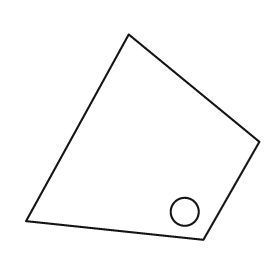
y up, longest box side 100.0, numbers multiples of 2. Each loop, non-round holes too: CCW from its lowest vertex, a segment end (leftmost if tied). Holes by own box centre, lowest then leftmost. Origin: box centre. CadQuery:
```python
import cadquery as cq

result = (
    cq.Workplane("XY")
    .moveTo(26.0, -44.0)
    .lineTo(50.0, -2.0)
    .lineTo(-6.0, 44.0)
    .lineTo(-50.0, -36.0)
    .close()
    .moveTo(18.0, -32.0)
    .circle(6.0)
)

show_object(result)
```